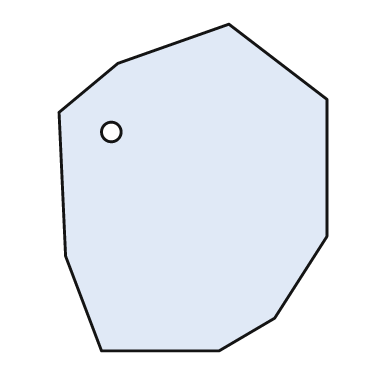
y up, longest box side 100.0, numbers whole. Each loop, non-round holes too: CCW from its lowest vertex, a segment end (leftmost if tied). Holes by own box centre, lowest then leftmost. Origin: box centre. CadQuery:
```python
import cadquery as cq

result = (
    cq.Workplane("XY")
    .moveTo(-28.0, -50.0)
    .lineTo(8.0, -50.0)
    .lineTo(25.0, -40.0)
    .lineTo(41.0, -15.0)
    .lineTo(41.0, 27.0)
    .lineTo(11.0, 50.0)
    .lineTo(-23.0, 38.0)
    .lineTo(-41.0, 23.0)
    .lineTo(-39.0, -21.0)
    .close()
    .moveTo(-25.0, 17.0)
    .circle(3.0)
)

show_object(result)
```